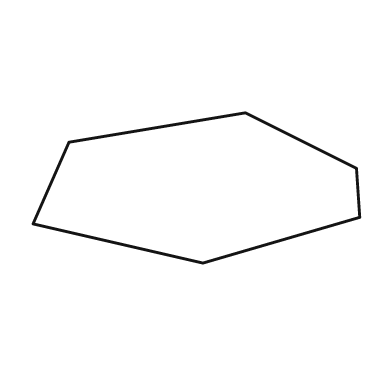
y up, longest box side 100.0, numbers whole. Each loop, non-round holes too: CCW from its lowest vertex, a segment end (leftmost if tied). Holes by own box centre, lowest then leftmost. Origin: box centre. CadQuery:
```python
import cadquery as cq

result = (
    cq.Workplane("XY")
    .moveTo(2.0, -23.0)
    .lineTo(50.0, -9.0)
    .lineTo(49.0, 6.0)
    .lineTo(15.0, 23.0)
    .lineTo(-39.0, 14.0)
    .lineTo(-50.0, -11.0)
    .close()
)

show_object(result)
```